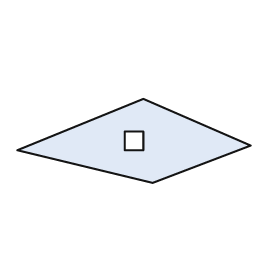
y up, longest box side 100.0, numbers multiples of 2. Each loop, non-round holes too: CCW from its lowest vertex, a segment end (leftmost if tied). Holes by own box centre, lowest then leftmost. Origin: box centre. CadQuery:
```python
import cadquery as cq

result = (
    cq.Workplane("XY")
    .moveTo(8.0, -18.0)
    .lineTo(50.0, -2.0)
    .lineTo(4.0, 18.0)
    .lineTo(-50.0, -4.0)
    .close()
    .moveTo(-4.0, -4.0)
    .lineTo(4.0, -4.0)
    .lineTo(4.0, 4.0)
    .lineTo(-4.0, 4.0)
    .close()
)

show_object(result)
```